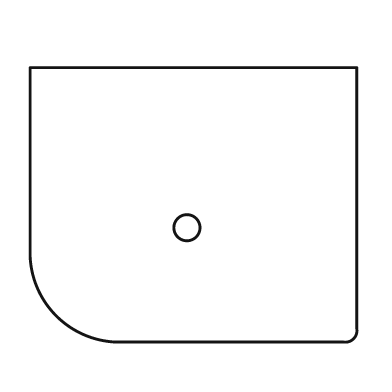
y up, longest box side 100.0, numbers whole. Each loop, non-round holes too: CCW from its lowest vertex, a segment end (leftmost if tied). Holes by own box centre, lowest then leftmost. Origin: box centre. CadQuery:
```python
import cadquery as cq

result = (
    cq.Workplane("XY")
    .moveTo(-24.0, -42.0)
    .lineTo(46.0, -42.0)
    .threePointArc((49.0, -41.0), (50.0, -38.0))
    .lineTo(50.0, 42.0)
    .lineTo(-50.0, 42.0)
    .lineTo(-50.0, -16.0)
    .threePointArc((-42.0, -34.0), (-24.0, -42.0))
    .close()
    .moveTo(-2.0, -7.0)
    .circle(4.0)
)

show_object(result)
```